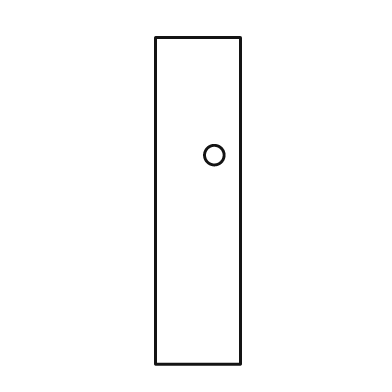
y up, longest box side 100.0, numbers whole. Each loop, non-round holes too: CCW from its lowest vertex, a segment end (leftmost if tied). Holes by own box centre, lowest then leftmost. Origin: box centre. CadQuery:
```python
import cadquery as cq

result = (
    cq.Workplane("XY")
    .moveTo(-13.0, -50.0)
    .lineTo(13.0, -50.0)
    .lineTo(13.0, 50.0)
    .lineTo(-13.0, 50.0)
    .close()
    .moveTo(5.0, 14.0)
    .circle(3.0)
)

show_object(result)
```